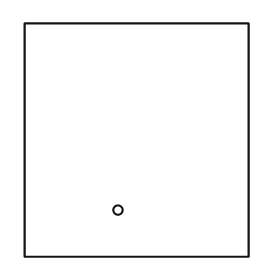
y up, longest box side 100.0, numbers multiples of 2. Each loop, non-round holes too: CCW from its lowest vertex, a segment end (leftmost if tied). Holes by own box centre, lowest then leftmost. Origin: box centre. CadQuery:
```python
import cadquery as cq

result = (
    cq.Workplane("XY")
    .moveTo(-48.0, -50.0)
    .lineTo(48.0, -50.0)
    .lineTo(48.0, 50.0)
    .lineTo(-48.0, 50.0)
    .close()
    .moveTo(-8.0, -30.0)
    .circle(2.0)
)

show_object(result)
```